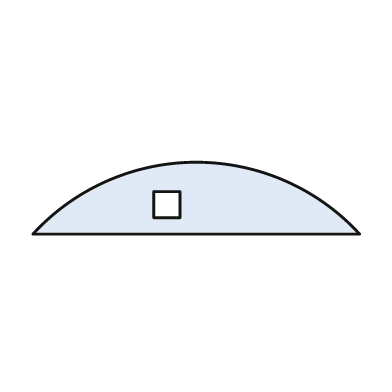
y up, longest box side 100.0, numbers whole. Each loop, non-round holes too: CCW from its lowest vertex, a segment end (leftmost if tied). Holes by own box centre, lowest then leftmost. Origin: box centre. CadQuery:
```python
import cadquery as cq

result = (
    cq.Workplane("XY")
    .moveTo(-50.0, -11.0)
    .lineTo(50.0, -11.0)
    .threePointArc((0.0, 11.0), (-50.0, -11.0))
    .close()
    .moveTo(-13.0, -6.0)
    .lineTo(-5.0, -6.0)
    .lineTo(-5.0, 2.0)
    .lineTo(-13.0, 2.0)
    .close()
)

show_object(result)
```